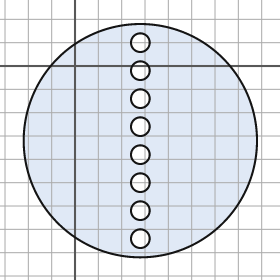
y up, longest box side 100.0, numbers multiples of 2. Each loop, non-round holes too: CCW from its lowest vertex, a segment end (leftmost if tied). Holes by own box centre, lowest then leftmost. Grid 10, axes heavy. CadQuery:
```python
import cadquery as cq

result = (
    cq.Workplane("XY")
    .moveTo(28.0, -32.0)
    .circle(50.0)
    .moveTo(28.0, -74.0)
    .circle(4.0)
    .moveTo(28.0, -62.0)
    .circle(4.0)
    .moveTo(28.0, -50.0)
    .circle(4.0)
    .moveTo(28.0, -38.0)
    .circle(4.0)
    .moveTo(28.0, -26.0)
    .circle(4.0)
    .moveTo(28.0, -14.0)
    .circle(4.0)
    .moveTo(28.0, -2.0)
    .circle(4.0)
    .moveTo(28.0, 10.0)
    .circle(4.0)
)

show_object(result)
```